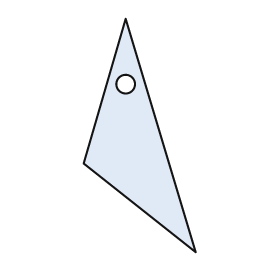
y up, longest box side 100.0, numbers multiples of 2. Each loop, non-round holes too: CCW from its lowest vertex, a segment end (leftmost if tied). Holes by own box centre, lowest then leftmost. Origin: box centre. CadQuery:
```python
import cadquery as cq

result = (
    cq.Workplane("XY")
    .moveTo(24.0, -50.0)
    .lineTo(-6.0, 50.0)
    .lineTo(-24.0, -12.0)
    .close()
    .moveTo(-6.0, 22.0)
    .circle(4.0)
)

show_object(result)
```